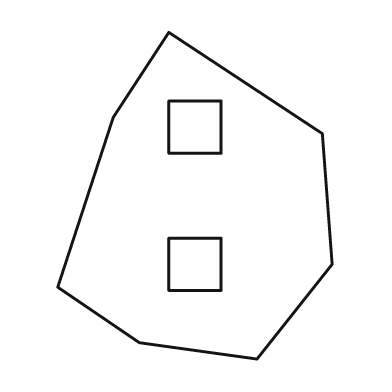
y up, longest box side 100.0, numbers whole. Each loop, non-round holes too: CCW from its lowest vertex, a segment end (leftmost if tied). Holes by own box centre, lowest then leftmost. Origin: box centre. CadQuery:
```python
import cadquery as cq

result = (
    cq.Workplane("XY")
    .moveTo(19.0, -50.0)
    .lineTo(42.0, -21.0)
    .lineTo(39.0, 19.0)
    .lineTo(-8.0, 50.0)
    .lineTo(-25.0, 24.0)
    .lineTo(-42.0, -28.0)
    .lineTo(-17.0, -45.0)
    .close()
    .moveTo(-8.0, -29.0)
    .lineTo(8.0, -29.0)
    .lineTo(8.0, -13.0)
    .lineTo(-8.0, -13.0)
    .close()
    .moveTo(-8.0, 13.0)
    .lineTo(8.0, 13.0)
    .lineTo(8.0, 29.0)
    .lineTo(-8.0, 29.0)
    .close()
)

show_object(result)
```